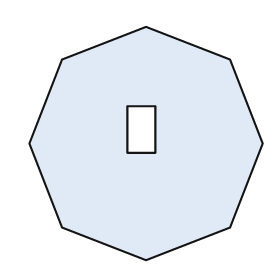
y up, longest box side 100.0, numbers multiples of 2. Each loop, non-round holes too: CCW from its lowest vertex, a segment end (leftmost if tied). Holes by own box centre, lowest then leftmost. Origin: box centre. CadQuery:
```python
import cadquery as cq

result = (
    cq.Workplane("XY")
    .moveTo(0.0, -50.0)
    .lineTo(36.0, -36.0)
    .lineTo(50.0, 0.0)
    .lineTo(36.0, 36.0)
    .lineTo(0.0, 50.0)
    .lineTo(-36.0, 36.0)
    .lineTo(-50.0, 0.0)
    .lineTo(-36.0, -36.0)
    .close()
    .moveTo(-8.0, -4.0)
    .lineTo(4.0, -4.0)
    .lineTo(4.0, 16.0)
    .lineTo(-8.0, 16.0)
    .close()
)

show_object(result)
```